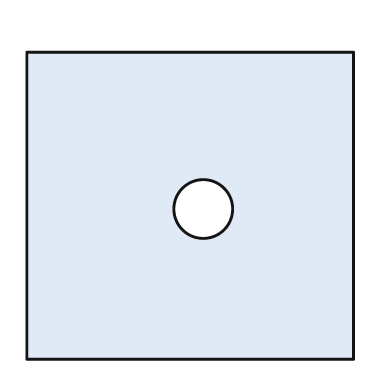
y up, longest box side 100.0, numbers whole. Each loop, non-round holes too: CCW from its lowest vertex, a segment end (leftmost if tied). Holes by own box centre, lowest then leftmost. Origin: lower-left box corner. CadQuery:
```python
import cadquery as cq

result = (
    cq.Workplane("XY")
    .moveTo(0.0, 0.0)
    .lineTo(100.0, 0.0)
    .lineTo(100.0, 94.0)
    .lineTo(0.0, 94.0)
    .close()
    .moveTo(54.0, 46.0)
    .circle(9.0)
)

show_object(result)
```